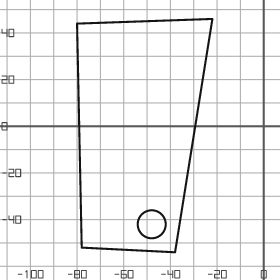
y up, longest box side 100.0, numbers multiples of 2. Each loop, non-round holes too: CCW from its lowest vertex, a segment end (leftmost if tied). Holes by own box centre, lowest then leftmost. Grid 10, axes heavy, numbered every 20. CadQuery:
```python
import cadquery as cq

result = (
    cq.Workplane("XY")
    .moveTo(-38.0, -54.0)
    .lineTo(-22.0, 46.0)
    .lineTo(-80.0, 44.0)
    .lineTo(-78.0, -52.0)
    .close()
    .moveTo(-48.0, -42.0)
    .circle(6.0)
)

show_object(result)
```